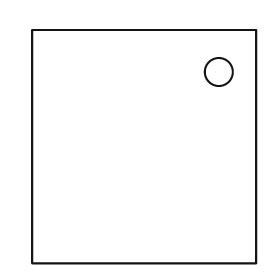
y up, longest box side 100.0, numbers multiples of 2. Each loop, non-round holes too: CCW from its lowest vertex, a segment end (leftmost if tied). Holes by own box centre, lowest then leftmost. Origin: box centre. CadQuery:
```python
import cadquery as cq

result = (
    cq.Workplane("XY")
    .moveTo(-48.0, -50.0)
    .lineTo(48.0, -50.0)
    .lineTo(48.0, 50.0)
    .lineTo(-48.0, 50.0)
    .close()
    .moveTo(32.0, 32.0)
    .circle(6.0)
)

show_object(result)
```